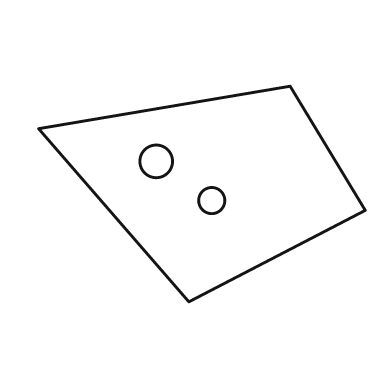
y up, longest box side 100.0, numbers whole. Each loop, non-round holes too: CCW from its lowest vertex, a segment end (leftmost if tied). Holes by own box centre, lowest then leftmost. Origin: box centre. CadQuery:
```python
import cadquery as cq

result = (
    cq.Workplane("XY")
    .moveTo(-4.0, -33.0)
    .lineTo(50.0, -5.0)
    .lineTo(27.0, 33.0)
    .lineTo(-50.0, 20.0)
    .close()
    .moveTo(3.0, -2.0)
    .circle(4.0)
    .moveTo(-14.0, 10.0)
    .circle(5.0)
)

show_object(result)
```